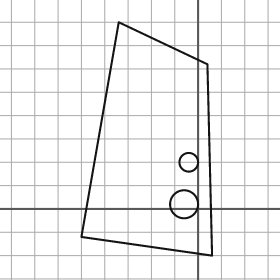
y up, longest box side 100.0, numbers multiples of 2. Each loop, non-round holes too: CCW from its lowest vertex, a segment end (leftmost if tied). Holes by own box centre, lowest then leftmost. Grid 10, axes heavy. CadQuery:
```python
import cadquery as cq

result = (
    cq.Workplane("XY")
    .moveTo(6.0, -20.0)
    .lineTo(4.0, 62.0)
    .lineTo(-34.0, 80.0)
    .lineTo(-50.0, -12.0)
    .close()
    .moveTo(-6.0, 2.0)
    .circle(6.0)
    .moveTo(-4.0, 20.0)
    .circle(4.0)
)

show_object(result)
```